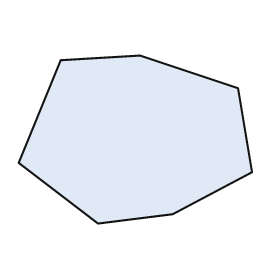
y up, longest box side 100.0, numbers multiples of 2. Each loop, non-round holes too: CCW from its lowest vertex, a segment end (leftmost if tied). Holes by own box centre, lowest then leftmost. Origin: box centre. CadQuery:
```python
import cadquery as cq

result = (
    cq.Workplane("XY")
    .moveTo(-16.0, -36.0)
    .lineTo(16.0, -32.0)
    .lineTo(50.0, -14.0)
    .lineTo(44.0, 22.0)
    .lineTo(2.0, 36.0)
    .lineTo(-32.0, 34.0)
    .lineTo(-50.0, -10.0)
    .close()
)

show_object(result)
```